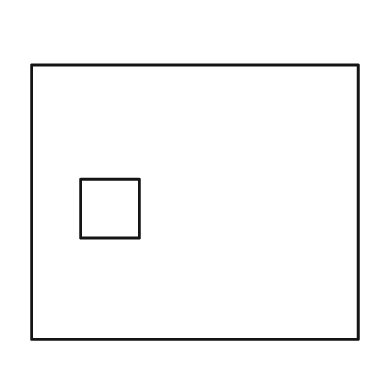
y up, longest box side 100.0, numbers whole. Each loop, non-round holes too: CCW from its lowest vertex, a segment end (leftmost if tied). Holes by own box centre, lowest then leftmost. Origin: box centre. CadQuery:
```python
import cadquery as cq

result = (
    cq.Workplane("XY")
    .moveTo(-50.0, -42.0)
    .lineTo(50.0, -42.0)
    .lineTo(50.0, 42.0)
    .lineTo(-50.0, 42.0)
    .close()
    .moveTo(-35.0, -11.0)
    .lineTo(-17.0, -11.0)
    .lineTo(-17.0, 7.0)
    .lineTo(-35.0, 7.0)
    .close()
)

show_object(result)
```